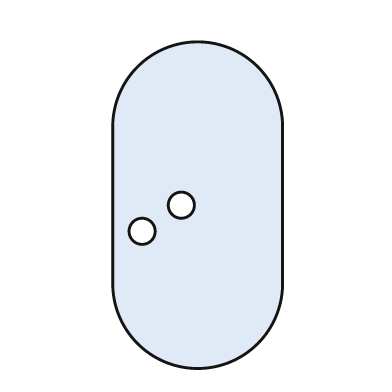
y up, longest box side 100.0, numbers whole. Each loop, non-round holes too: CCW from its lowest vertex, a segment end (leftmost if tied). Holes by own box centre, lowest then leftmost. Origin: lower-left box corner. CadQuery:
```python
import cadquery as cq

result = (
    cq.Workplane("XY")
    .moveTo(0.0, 26.0)
    .threePointArc((26.0, 0.0), (52.0, 26.0))
    .lineTo(52.0, 74.0)
    .threePointArc((26.0, 100.0), (0.0, 74.0))
    .close()
    .moveTo(9.0, 42.0)
    .circle(4.0)
    .moveTo(21.0, 50.0)
    .circle(4.0)
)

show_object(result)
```